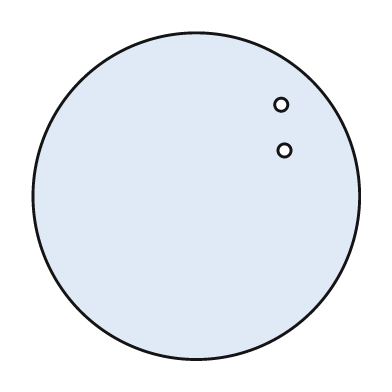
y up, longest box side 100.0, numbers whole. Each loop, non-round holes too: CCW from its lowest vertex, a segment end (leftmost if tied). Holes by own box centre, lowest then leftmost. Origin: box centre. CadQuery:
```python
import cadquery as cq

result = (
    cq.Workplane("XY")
    .moveTo(0.0, 0.0)
    .circle(50.0)
    .moveTo(27.0, 14.0)
    .circle(2.0)
    .moveTo(26.0, 28.0)
    .circle(2.0)
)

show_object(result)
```